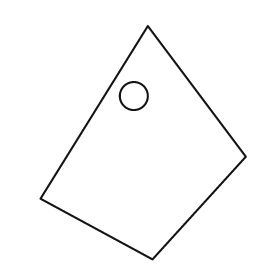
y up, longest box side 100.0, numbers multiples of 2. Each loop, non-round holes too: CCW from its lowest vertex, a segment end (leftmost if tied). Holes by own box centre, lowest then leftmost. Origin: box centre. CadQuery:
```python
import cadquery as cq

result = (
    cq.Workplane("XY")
    .moveTo(4.0, -50.0)
    .lineTo(44.0, -6.0)
    .lineTo(2.0, 50.0)
    .lineTo(-44.0, -24.0)
    .close()
    .moveTo(-4.0, 20.0)
    .circle(6.0)
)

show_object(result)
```